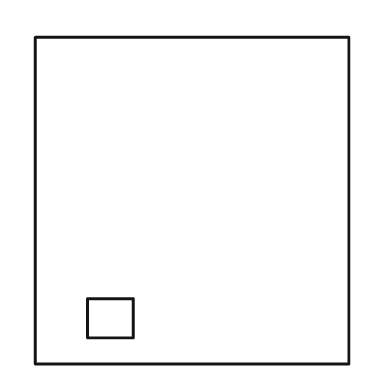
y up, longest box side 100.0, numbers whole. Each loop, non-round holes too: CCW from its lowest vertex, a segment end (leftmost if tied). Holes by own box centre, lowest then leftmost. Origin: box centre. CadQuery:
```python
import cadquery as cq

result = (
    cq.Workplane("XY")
    .moveTo(-48.0, -50.0)
    .lineTo(48.0, -50.0)
    .lineTo(48.0, 50.0)
    .lineTo(-48.0, 50.0)
    .close()
    .moveTo(-32.0, -42.0)
    .lineTo(-18.0, -42.0)
    .lineTo(-18.0, -30.0)
    .lineTo(-32.0, -30.0)
    .close()
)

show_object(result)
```